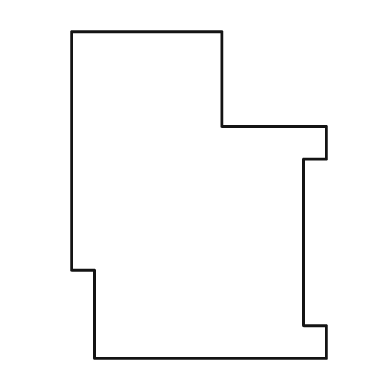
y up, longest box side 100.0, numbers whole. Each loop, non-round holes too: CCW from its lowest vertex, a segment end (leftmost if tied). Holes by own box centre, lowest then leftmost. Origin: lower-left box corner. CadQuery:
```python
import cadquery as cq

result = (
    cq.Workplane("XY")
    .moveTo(7.0, 0.0)
    .lineTo(78.0, 0.0)
    .lineTo(78.0, 10.0)
    .lineTo(71.0, 10.0)
    .lineTo(71.0, 61.0)
    .lineTo(78.0, 61.0)
    .lineTo(78.0, 71.0)
    .lineTo(46.0, 71.0)
    .lineTo(46.0, 100.0)
    .lineTo(0.0, 100.0)
    .lineTo(0.0, 27.0)
    .lineTo(7.0, 27.0)
    .close()
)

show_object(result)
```